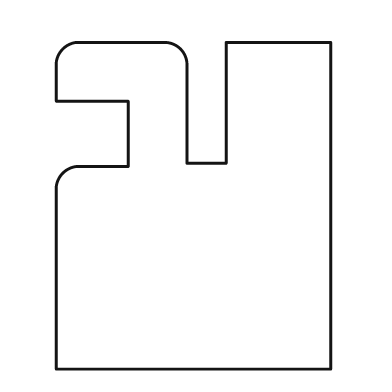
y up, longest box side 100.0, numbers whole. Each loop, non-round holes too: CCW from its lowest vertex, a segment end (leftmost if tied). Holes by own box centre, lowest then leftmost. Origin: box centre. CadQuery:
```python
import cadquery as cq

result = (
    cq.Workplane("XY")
    .moveTo(-42.0, -50.0)
    .lineTo(42.0, -50.0)
    .lineTo(42.0, 50.0)
    .lineTo(10.0, 50.0)
    .lineTo(10.0, 13.0)
    .lineTo(-2.0, 13.0)
    .lineTo(-2.0, 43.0)
    .threePointArc((-4.0, 48.0), (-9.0, 50.0))
    .lineTo(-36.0, 50.0)
    .threePointArc((-40.0, 48.0), (-42.0, 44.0))
    .lineTo(-42.0, 32.0)
    .lineTo(-20.0, 32.0)
    .lineTo(-20.0, 12.0)
    .lineTo(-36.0, 12.0)
    .threePointArc((-40.0, 10.0), (-42.0, 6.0))
    .close()
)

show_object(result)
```